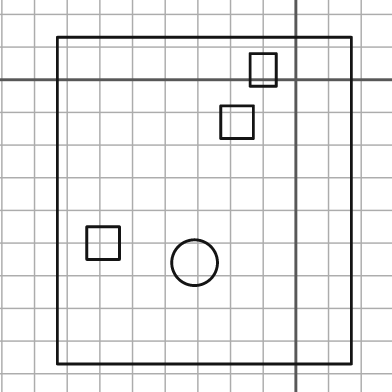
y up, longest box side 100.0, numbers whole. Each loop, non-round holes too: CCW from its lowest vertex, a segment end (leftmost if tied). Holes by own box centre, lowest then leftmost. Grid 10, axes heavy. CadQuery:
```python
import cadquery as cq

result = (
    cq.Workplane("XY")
    .moveTo(-73.0, -87.0)
    .lineTo(17.0, -87.0)
    .lineTo(17.0, 13.0)
    .lineTo(-73.0, 13.0)
    .close()
    .moveTo(-31.0, -56.0)
    .circle(7.0)
    .moveTo(-64.0, -55.0)
    .lineTo(-54.0, -55.0)
    .lineTo(-54.0, -45.0)
    .lineTo(-64.0, -45.0)
    .close()
    .moveTo(-23.0, -18.0)
    .lineTo(-13.0, -18.0)
    .lineTo(-13.0, -8.0)
    .lineTo(-23.0, -8.0)
    .close()
    .moveTo(-14.0, -2.0)
    .lineTo(-6.0, -2.0)
    .lineTo(-6.0, 8.0)
    .lineTo(-14.0, 8.0)
    .close()
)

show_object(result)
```